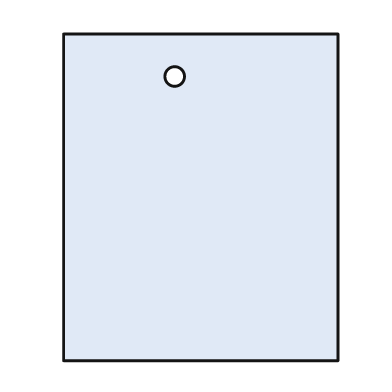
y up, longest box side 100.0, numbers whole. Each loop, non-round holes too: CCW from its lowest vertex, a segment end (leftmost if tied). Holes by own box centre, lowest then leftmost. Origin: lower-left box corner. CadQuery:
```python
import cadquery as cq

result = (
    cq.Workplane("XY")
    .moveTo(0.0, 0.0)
    .lineTo(84.0, 0.0)
    .lineTo(84.0, 100.0)
    .lineTo(0.0, 100.0)
    .close()
    .moveTo(34.0, 87.0)
    .circle(3.0)
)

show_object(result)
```